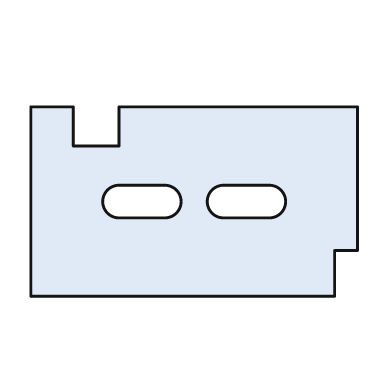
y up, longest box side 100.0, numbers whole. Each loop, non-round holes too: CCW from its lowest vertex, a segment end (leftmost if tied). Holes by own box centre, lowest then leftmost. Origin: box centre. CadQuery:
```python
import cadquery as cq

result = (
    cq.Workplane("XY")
    .moveTo(-50.0, -29.0)
    .lineTo(43.0, -29.0)
    .lineTo(43.0, -15.0)
    .lineTo(50.0, -15.0)
    .lineTo(50.0, 29.0)
    .lineTo(-23.0, 29.0)
    .lineTo(-23.0, 17.0)
    .lineTo(-37.0, 17.0)
    .lineTo(-37.0, 29.0)
    .lineTo(-50.0, 29.0)
    .close()
    .moveTo(-23.0, -5.0)
    .lineTo(-9.0, -5.0)
    .threePointArc((-4.0, 0.0), (-9.0, 5.0))
    .lineTo(-23.0, 5.0)
    .threePointArc((-28.0, 0.0), (-23.0, -5.0))
    .close()
    .moveTo(9.0, -5.0)
    .lineTo(23.0, -5.0)
    .threePointArc((28.0, 0.0), (23.0, 5.0))
    .lineTo(9.0, 5.0)
    .threePointArc((4.0, 0.0), (9.0, -5.0))
    .close()
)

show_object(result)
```